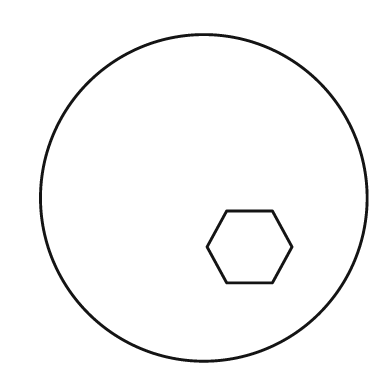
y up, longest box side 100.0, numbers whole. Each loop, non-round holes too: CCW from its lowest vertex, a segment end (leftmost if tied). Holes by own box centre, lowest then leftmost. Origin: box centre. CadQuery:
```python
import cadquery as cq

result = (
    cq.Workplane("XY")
    .moveTo(0.0, 0.0)
    .circle(50.0)
    .moveTo(7.0, -26.0)
    .lineTo(21.0, -26.0)
    .lineTo(27.0, -15.0)
    .lineTo(21.0, -4.0)
    .lineTo(7.0, -4.0)
    .lineTo(1.0, -15.0)
    .close()
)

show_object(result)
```